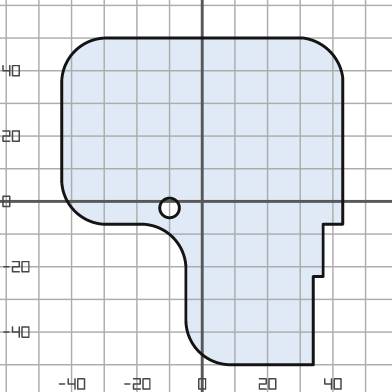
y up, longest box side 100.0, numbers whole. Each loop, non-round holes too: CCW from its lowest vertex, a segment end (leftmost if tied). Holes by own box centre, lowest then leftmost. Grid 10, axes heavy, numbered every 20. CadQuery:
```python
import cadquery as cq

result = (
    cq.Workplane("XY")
    .moveTo(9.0, -50.0)
    .lineTo(34.0, -50.0)
    .lineTo(34.0, -23.0)
    .lineTo(37.0, -23.0)
    .lineTo(37.0, -7.0)
    .lineTo(43.0, -7.0)
    .lineTo(43.0, 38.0)
    .threePointArc((39.0, 46.0), (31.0, 50.0))
    .lineTo(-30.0, 50.0)
    .threePointArc((-39.0, 46.0), (-43.0, 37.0))
    .lineTo(-43.0, 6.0)
    .threePointArc((-39.0, -3.0), (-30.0, -7.0))
    .lineTo(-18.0, -7.0)
    .threePointArc((-9.0, -11.0), (-5.0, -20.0))
    .lineTo(-5.0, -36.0)
    .threePointArc((-1.0, -46.0), (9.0, -50.0))
    .close()
    .moveTo(-10.0, -2.0)
    .circle(3.0)
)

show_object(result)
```